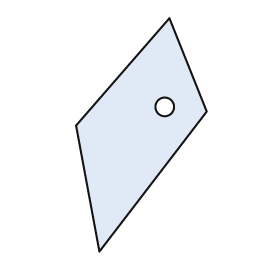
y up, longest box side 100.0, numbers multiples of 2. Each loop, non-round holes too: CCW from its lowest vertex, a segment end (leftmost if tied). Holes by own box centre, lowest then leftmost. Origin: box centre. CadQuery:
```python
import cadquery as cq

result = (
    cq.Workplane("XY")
    .moveTo(-18.0, -50.0)
    .lineTo(28.0, 10.0)
    .lineTo(12.0, 50.0)
    .lineTo(-28.0, 4.0)
    .close()
    .moveTo(10.0, 12.0)
    .circle(4.0)
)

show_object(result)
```